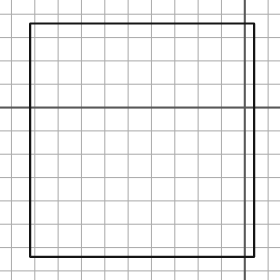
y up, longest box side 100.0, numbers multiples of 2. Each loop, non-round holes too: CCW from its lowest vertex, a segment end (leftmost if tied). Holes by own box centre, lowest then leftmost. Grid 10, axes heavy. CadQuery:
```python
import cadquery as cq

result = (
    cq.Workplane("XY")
    .moveTo(-92.0, -64.0)
    .lineTo(4.0, -64.0)
    .lineTo(4.0, 36.0)
    .lineTo(-92.0, 36.0)
    .close()
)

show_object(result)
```